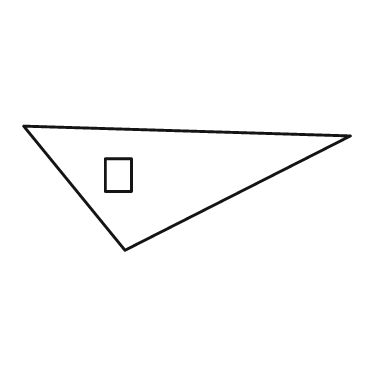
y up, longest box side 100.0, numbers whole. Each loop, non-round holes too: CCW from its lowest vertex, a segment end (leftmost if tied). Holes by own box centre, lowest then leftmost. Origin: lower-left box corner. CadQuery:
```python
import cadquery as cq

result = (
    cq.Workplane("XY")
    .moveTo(31.0, 0.0)
    .lineTo(100.0, 35.0)
    .lineTo(0.0, 38.0)
    .close()
    .moveTo(25.0, 18.0)
    .lineTo(33.0, 18.0)
    .lineTo(33.0, 28.0)
    .lineTo(25.0, 28.0)
    .close()
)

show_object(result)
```